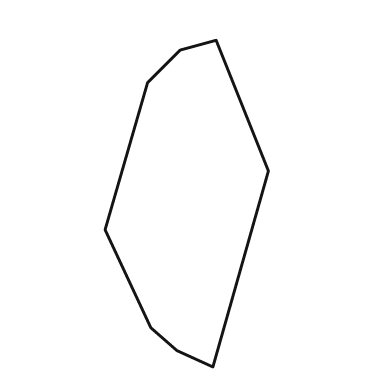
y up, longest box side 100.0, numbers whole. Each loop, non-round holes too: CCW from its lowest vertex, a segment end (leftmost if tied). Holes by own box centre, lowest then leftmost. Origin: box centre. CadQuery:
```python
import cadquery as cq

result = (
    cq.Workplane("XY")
    .moveTo(8.0, -50.0)
    .lineTo(25.0, 10.0)
    .lineTo(9.0, 50.0)
    .lineTo(-2.0, 47.0)
    .lineTo(-12.0, 37.0)
    .lineTo(-25.0, -8.0)
    .lineTo(-11.0, -38.0)
    .lineTo(-3.0, -45.0)
    .close()
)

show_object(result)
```